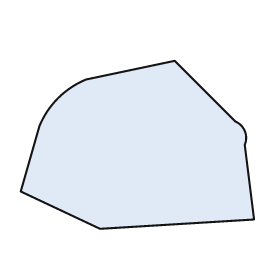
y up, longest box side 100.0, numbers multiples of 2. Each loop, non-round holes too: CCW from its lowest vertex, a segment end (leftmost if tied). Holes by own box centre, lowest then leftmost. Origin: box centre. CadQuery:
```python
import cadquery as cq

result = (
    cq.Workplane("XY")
    .moveTo(-16.0, -36.0)
    .lineTo(50.0, -32.0)
    .lineTo(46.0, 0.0)
    .threePointArc((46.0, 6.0), (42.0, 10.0))
    .lineTo(16.0, 36.0)
    .lineTo(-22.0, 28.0)
    .threePointArc((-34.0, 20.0), (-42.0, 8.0))
    .lineTo(-50.0, -20.0)
    .close()
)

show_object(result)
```